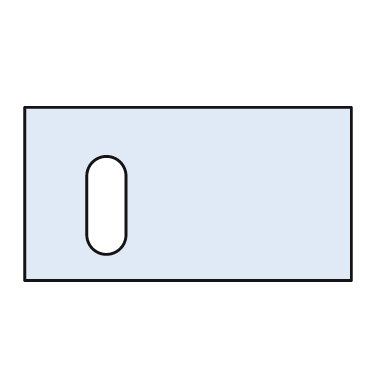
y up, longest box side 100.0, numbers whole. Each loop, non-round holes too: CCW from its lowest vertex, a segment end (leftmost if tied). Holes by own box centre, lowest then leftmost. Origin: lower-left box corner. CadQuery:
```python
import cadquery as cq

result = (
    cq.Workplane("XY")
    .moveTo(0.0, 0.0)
    .lineTo(100.0, 0.0)
    .lineTo(100.0, 53.0)
    .lineTo(0.0, 53.0)
    .close()
    .moveTo(19.0, 14.0)
    .threePointArc((25.0, 8.0), (31.0, 14.0))
    .lineTo(31.0, 32.0)
    .threePointArc((25.0, 38.0), (19.0, 32.0))
    .close()
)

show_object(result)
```